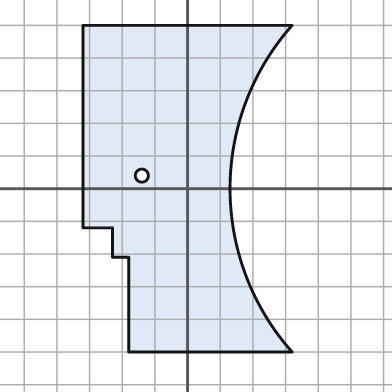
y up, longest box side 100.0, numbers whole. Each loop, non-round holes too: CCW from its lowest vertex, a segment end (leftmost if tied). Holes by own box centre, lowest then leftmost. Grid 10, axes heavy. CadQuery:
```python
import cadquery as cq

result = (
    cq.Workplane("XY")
    .moveTo(-18.0, -50.0)
    .lineTo(32.0, -50.0)
    .threePointArc((13.0, 0.0), (32.0, 50.0))
    .lineTo(-32.0, 50.0)
    .lineTo(-32.0, -12.0)
    .lineTo(-23.0, -12.0)
    .lineTo(-23.0, -21.0)
    .lineTo(-18.0, -21.0)
    .close()
    .moveTo(-14.0, 4.0)
    .circle(2.0)
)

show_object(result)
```